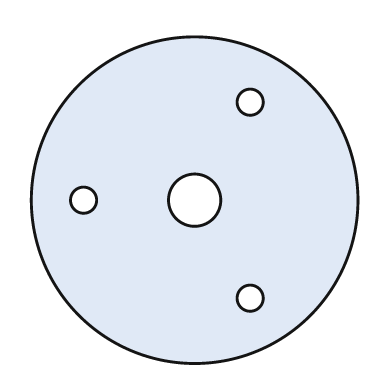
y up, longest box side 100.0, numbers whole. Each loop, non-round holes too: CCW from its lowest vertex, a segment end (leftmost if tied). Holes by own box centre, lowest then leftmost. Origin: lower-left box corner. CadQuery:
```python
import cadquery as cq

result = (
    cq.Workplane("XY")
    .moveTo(50.0, 50.0)
    .circle(50.0)
    .moveTo(67.0, 20.0)
    .circle(4.0)
    .moveTo(16.0, 50.0)
    .circle(4.0)
    .moveTo(50.0, 50.0)
    .circle(8.0)
    .moveTo(67.0, 80.0)
    .circle(4.0)
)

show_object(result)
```